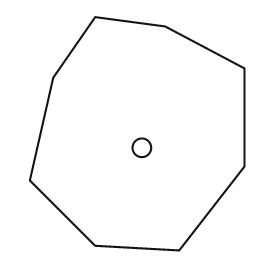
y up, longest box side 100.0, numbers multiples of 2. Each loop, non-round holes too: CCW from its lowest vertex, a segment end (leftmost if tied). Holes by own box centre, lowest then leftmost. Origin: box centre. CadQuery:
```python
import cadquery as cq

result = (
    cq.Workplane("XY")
    .moveTo(18.0, -50.0)
    .lineTo(46.0, -14.0)
    .lineTo(46.0, 28.0)
    .lineTo(12.0, 46.0)
    .lineTo(-18.0, 50.0)
    .lineTo(-36.0, 24.0)
    .lineTo(-46.0, -20.0)
    .lineTo(-18.0, -48.0)
    .close()
    .moveTo(2.0, -6.0)
    .circle(4.0)
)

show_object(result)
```